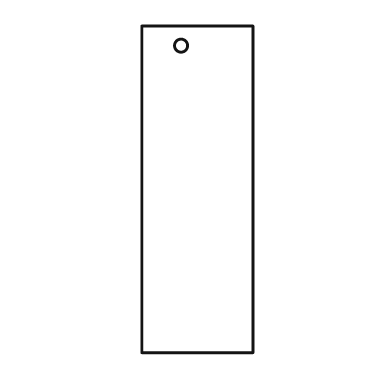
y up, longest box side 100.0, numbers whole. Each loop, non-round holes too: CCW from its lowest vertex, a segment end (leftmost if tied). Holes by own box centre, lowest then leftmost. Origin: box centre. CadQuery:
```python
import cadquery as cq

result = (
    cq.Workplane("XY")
    .moveTo(-17.0, -50.0)
    .lineTo(17.0, -50.0)
    .lineTo(17.0, 50.0)
    .lineTo(-17.0, 50.0)
    .close()
    .moveTo(-5.0, 44.0)
    .circle(2.0)
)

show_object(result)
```